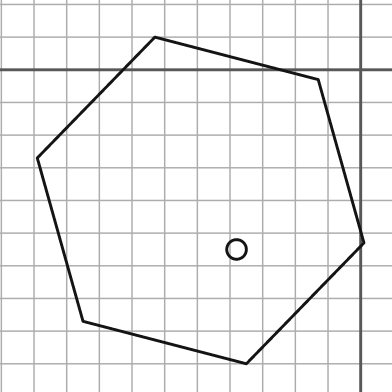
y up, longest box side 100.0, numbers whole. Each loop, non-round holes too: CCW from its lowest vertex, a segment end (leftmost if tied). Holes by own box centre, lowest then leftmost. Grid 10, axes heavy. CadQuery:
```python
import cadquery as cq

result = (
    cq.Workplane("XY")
    .moveTo(-35.0, -90.0)
    .lineTo(1.0, -53.0)
    .lineTo(-13.0, -3.0)
    .lineTo(-63.0, 10.0)
    .lineTo(-99.0, -27.0)
    .lineTo(-85.0, -77.0)
    .close()
    .moveTo(-38.0, -55.0)
    .circle(3.0)
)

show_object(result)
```